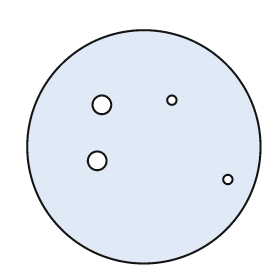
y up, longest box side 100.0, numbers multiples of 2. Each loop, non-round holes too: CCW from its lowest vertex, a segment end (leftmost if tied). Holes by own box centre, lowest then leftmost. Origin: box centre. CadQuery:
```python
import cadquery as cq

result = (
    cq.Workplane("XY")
    .moveTo(0.0, 0.0)
    .circle(50.0)
    .moveTo(36.0, -14.0)
    .circle(2.0)
    .moveTo(-20.0, -6.0)
    .circle(4.0)
    .moveTo(-18.0, 18.0)
    .circle(4.0)
    .moveTo(12.0, 20.0)
    .circle(2.0)
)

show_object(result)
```